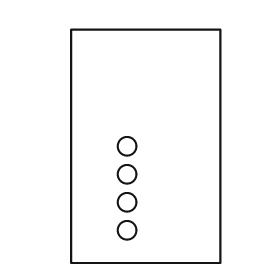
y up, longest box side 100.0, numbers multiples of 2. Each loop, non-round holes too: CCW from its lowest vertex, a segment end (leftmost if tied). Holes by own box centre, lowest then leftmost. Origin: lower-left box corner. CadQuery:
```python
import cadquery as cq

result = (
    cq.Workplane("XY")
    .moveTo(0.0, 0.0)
    .lineTo(64.0, 0.0)
    .lineTo(64.0, 100.0)
    .lineTo(0.0, 100.0)
    .close()
    .moveTo(24.0, 14.0)
    .circle(4.0)
    .moveTo(24.0, 26.0)
    .circle(4.0)
    .moveTo(24.0, 38.0)
    .circle(4.0)
    .moveTo(24.0, 50.0)
    .circle(4.0)
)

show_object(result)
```